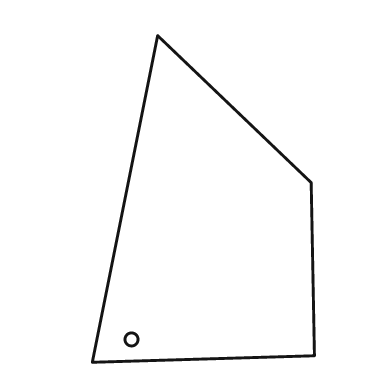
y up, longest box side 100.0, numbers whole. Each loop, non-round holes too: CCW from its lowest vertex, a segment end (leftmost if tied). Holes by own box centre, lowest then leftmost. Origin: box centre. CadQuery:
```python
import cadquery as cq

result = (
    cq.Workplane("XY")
    .moveTo(-34.0, -50.0)
    .lineTo(34.0, -48.0)
    .lineTo(33.0, 5.0)
    .lineTo(-14.0, 50.0)
    .close()
    .moveTo(-22.0, -43.0)
    .circle(2.0)
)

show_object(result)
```